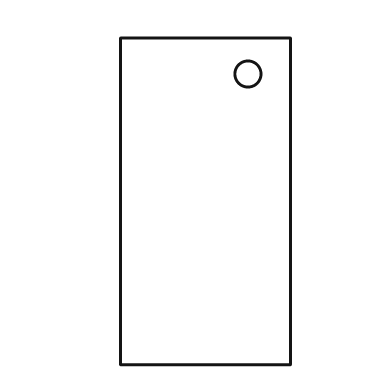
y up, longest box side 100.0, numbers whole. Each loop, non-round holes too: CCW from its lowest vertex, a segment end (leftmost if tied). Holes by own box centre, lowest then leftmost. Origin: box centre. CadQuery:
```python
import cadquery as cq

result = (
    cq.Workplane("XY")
    .moveTo(-26.0, -50.0)
    .lineTo(26.0, -50.0)
    .lineTo(26.0, 50.0)
    .lineTo(-26.0, 50.0)
    .close()
    .moveTo(13.0, 39.0)
    .circle(4.0)
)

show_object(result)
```